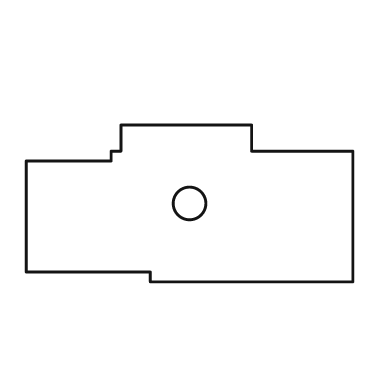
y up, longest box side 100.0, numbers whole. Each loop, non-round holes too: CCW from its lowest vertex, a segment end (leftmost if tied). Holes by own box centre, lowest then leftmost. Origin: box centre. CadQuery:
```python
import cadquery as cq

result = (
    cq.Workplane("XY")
    .moveTo(-12.0, -24.0)
    .lineTo(50.0, -24.0)
    .lineTo(50.0, 16.0)
    .lineTo(19.0, 16.0)
    .lineTo(19.0, 24.0)
    .lineTo(-21.0, 24.0)
    .lineTo(-21.0, 16.0)
    .lineTo(-24.0, 16.0)
    .lineTo(-24.0, 13.0)
    .lineTo(-50.0, 13.0)
    .lineTo(-50.0, -21.0)
    .lineTo(-12.0, -21.0)
    .close()
    .moveTo(0.0, 0.0)
    .circle(5.0)
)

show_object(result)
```